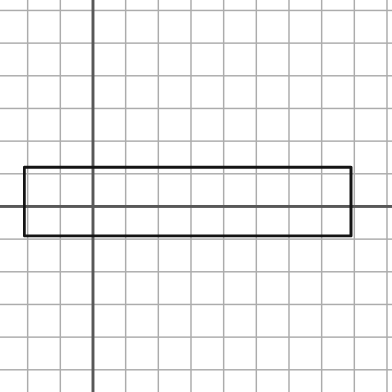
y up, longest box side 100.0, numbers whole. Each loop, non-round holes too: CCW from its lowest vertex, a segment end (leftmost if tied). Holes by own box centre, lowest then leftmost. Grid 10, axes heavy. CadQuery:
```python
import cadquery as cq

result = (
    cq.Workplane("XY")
    .moveTo(-21.0, -9.0)
    .lineTo(79.0, -9.0)
    .lineTo(79.0, 12.0)
    .lineTo(-21.0, 12.0)
    .close()
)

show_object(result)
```